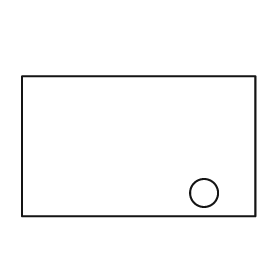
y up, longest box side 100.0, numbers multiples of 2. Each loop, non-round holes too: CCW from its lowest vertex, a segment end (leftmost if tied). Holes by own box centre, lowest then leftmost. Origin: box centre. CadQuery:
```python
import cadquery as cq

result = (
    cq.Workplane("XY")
    .moveTo(-50.0, -30.0)
    .lineTo(50.0, -30.0)
    .lineTo(50.0, 30.0)
    .lineTo(-50.0, 30.0)
    .close()
    .moveTo(28.0, -20.0)
    .circle(6.0)
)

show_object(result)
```